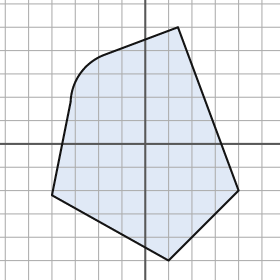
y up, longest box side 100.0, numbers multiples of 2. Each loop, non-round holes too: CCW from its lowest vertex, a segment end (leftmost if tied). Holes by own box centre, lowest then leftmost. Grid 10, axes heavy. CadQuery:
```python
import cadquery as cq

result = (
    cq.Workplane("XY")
    .moveTo(10.0, -50.0)
    .lineTo(40.0, -20.0)
    .lineTo(14.0, 50.0)
    .lineTo(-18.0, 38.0)
    .threePointArc((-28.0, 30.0), (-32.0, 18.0))
    .lineTo(-40.0, -22.0)
    .close()
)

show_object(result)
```